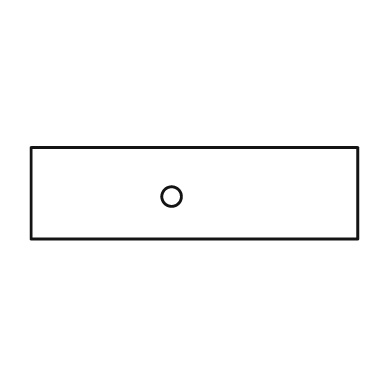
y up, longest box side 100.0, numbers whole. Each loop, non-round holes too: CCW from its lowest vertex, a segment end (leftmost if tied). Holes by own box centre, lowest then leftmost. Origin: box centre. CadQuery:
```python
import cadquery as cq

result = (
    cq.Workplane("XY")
    .moveTo(-50.0, -14.0)
    .lineTo(50.0, -14.0)
    .lineTo(50.0, 14.0)
    .lineTo(-50.0, 14.0)
    .close()
    .moveTo(-7.0, -1.0)
    .circle(3.0)
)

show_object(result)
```